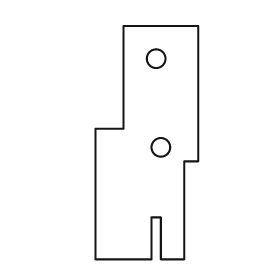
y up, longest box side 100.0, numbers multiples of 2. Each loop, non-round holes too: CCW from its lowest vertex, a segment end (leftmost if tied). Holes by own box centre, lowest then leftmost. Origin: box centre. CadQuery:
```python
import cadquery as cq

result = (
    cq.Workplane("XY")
    .moveTo(-22.0, -50.0)
    .lineTo(2.0, -50.0)
    .lineTo(2.0, -32.0)
    .lineTo(6.0, -32.0)
    .lineTo(6.0, -50.0)
    .lineTo(16.0, -50.0)
    .lineTo(16.0, -8.0)
    .lineTo(22.0, -8.0)
    .lineTo(22.0, 50.0)
    .lineTo(-10.0, 50.0)
    .lineTo(-10.0, 6.0)
    .lineTo(-22.0, 6.0)
    .close()
    .moveTo(6.0, -2.0)
    .circle(4.0)
    .moveTo(4.0, 36.0)
    .circle(4.0)
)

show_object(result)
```